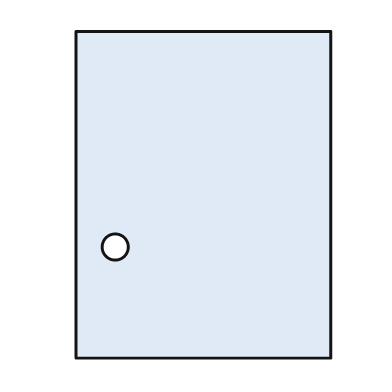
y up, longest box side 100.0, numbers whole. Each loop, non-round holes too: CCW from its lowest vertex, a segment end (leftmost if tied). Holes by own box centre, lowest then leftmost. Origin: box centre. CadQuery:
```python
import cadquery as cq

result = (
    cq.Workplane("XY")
    .moveTo(-39.0, -50.0)
    .lineTo(39.0, -50.0)
    .lineTo(39.0, 50.0)
    .lineTo(-39.0, 50.0)
    .close()
    .moveTo(-27.0, -16.0)
    .circle(4.0)
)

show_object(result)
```